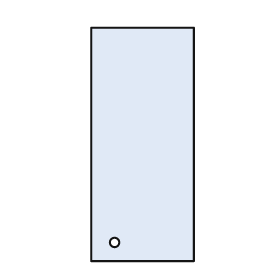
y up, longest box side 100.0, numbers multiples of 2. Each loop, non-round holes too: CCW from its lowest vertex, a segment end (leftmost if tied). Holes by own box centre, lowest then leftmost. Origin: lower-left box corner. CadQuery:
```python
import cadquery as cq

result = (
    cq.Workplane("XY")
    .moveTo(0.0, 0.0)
    .lineTo(44.0, 0.0)
    .lineTo(44.0, 100.0)
    .lineTo(0.0, 100.0)
    .close()
    .moveTo(10.0, 8.0)
    .circle(2.0)
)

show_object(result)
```